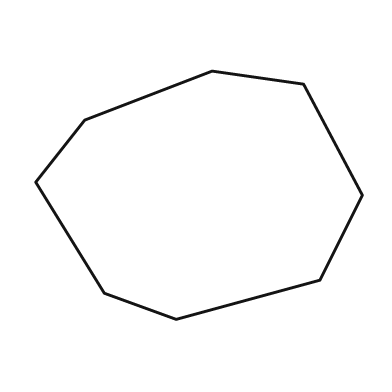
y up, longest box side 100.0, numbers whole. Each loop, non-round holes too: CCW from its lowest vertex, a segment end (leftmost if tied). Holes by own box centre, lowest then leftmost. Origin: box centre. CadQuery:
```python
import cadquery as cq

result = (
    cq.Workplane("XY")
    .moveTo(-7.0, -38.0)
    .lineTo(37.0, -26.0)
    .lineTo(50.0, 0.0)
    .lineTo(32.0, 34.0)
    .lineTo(4.0, 38.0)
    .lineTo(-35.0, 23.0)
    .lineTo(-50.0, 4.0)
    .lineTo(-29.0, -30.0)
    .close()
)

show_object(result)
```